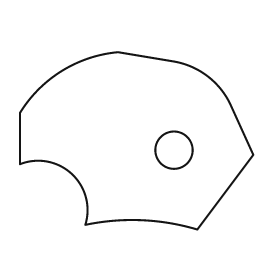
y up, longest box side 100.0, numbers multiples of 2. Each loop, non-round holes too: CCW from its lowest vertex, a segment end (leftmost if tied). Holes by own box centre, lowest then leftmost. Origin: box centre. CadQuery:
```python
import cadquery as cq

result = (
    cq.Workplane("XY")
    .moveTo(26.0, -38.0)
    .lineTo(50.0, -6.0)
    .lineTo(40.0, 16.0)
    .threePointArc((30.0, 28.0), (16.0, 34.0))
    .lineTo(-8.0, 38.0)
    .threePointArc((-32.0, 30.0), (-50.0, 12.0))
    .lineTo(-50.0, -10.0)
    .threePointArc((-28.0, -14.0), (-22.0, -36.0))
    .threePointArc((2.0, -34.0), (26.0, -38.0))
    .close()
    .moveTo(16.0, -4.0)
    .circle(8.0)
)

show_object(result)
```